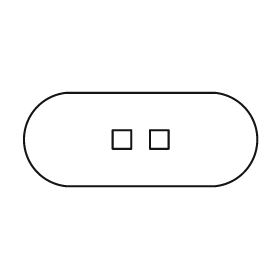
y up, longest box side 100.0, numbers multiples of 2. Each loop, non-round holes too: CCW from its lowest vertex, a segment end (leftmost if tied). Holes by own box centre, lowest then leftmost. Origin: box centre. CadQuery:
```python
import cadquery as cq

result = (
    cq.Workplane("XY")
    .moveTo(-32.0, -20.0)
    .lineTo(32.0, -20.0)
    .threePointArc((50.0, 0.0), (32.0, 20.0))
    .lineTo(-32.0, 20.0)
    .threePointArc((-50.0, 0.0), (-32.0, -20.0))
    .close()
    .moveTo(-12.0, -4.0)
    .lineTo(-4.0, -4.0)
    .lineTo(-4.0, 4.0)
    .lineTo(-12.0, 4.0)
    .close()
    .moveTo(4.0, -4.0)
    .lineTo(12.0, -4.0)
    .lineTo(12.0, 4.0)
    .lineTo(4.0, 4.0)
    .close()
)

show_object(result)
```